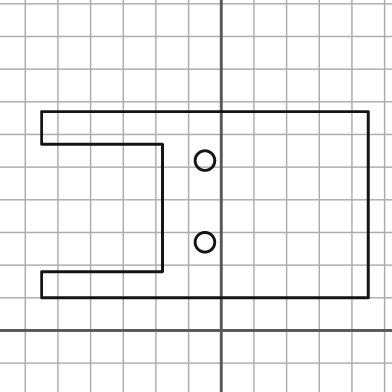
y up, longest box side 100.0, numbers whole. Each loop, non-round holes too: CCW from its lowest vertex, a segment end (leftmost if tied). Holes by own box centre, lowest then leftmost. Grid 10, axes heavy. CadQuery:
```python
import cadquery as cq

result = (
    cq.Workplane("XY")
    .moveTo(-55.0, 10.0)
    .lineTo(45.0, 10.0)
    .lineTo(45.0, 67.0)
    .lineTo(-55.0, 67.0)
    .lineTo(-55.0, 57.0)
    .lineTo(-18.0, 57.0)
    .lineTo(-18.0, 18.0)
    .lineTo(-55.0, 18.0)
    .close()
    .moveTo(-5.0, 27.0)
    .circle(3.0)
    .moveTo(-5.0, 52.0)
    .circle(3.0)
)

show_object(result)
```